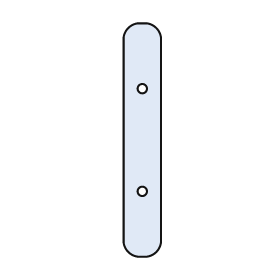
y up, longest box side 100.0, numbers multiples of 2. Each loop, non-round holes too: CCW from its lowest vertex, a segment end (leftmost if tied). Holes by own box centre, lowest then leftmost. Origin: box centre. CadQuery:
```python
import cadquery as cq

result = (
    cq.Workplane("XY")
    .moveTo(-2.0, -50.0)
    .lineTo(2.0, -50.0)
    .threePointArc((6.0, -48.0), (8.0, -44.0))
    .lineTo(8.0, 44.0)
    .threePointArc((6.0, 48.0), (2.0, 50.0))
    .lineTo(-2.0, 50.0)
    .threePointArc((-6.0, 48.0), (-8.0, 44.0))
    .lineTo(-8.0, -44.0)
    .threePointArc((-6.0, -48.0), (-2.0, -50.0))
    .close()
    .moveTo(0.0, -22.0)
    .circle(2.0)
    .moveTo(0.0, 22.0)
    .circle(2.0)
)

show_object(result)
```